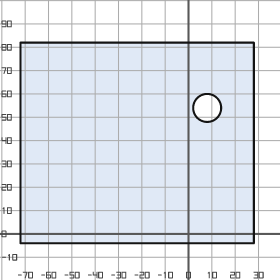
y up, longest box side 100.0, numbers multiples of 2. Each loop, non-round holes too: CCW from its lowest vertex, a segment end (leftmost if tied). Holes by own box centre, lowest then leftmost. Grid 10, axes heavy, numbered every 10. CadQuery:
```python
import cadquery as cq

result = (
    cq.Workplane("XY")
    .moveTo(-72.0, -4.0)
    .lineTo(28.0, -4.0)
    .lineTo(28.0, 82.0)
    .lineTo(-72.0, 82.0)
    .close()
    .moveTo(8.0, 54.0)
    .circle(6.0)
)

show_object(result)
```